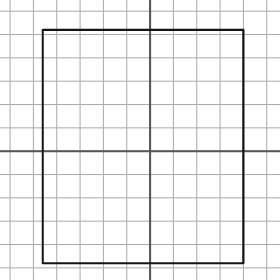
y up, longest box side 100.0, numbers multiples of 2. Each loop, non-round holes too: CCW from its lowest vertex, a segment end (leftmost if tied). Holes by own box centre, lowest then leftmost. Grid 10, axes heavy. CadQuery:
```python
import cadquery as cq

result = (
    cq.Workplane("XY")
    .moveTo(-46.0, -48.0)
    .lineTo(40.0, -48.0)
    .lineTo(40.0, 52.0)
    .lineTo(-46.0, 52.0)
    .close()
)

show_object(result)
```